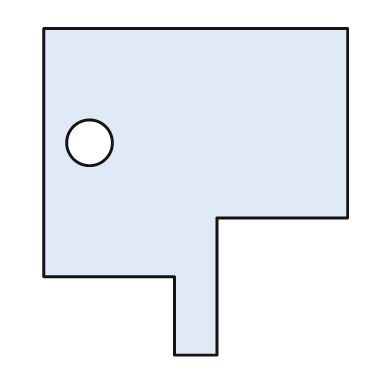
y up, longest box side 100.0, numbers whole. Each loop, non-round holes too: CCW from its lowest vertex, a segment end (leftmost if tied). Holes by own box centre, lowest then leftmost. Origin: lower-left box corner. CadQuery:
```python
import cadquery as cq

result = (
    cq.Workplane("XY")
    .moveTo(40.0, 0.0)
    .lineTo(53.0, 0.0)
    .lineTo(53.0, 42.0)
    .lineTo(93.0, 42.0)
    .lineTo(93.0, 100.0)
    .lineTo(0.0, 100.0)
    .lineTo(0.0, 24.0)
    .lineTo(40.0, 24.0)
    .close()
    .moveTo(14.0, 65.0)
    .circle(7.0)
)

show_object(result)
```